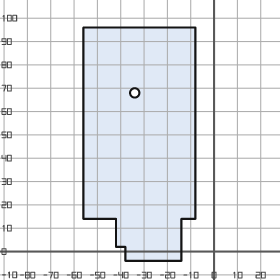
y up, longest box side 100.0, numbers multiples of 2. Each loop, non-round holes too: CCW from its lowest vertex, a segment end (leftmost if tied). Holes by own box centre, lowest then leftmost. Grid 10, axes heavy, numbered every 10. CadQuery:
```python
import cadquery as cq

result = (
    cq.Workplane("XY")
    .moveTo(-38.0, -4.0)
    .lineTo(-14.0, -4.0)
    .lineTo(-14.0, 14.0)
    .lineTo(-8.0, 14.0)
    .lineTo(-8.0, 96.0)
    .lineTo(-56.0, 96.0)
    .lineTo(-56.0, 14.0)
    .lineTo(-42.0, 14.0)
    .lineTo(-42.0, 2.0)
    .lineTo(-38.0, 2.0)
    .close()
    .moveTo(-34.0, 68.0)
    .circle(2.0)
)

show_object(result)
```